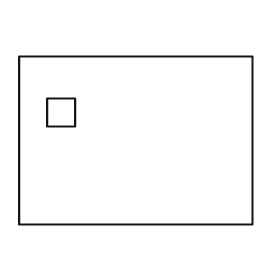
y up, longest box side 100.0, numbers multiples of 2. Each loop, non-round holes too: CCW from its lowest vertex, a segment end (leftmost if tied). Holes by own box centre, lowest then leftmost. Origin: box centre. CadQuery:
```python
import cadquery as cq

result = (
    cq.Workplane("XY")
    .moveTo(-50.0, -36.0)
    .lineTo(50.0, -36.0)
    .lineTo(50.0, 36.0)
    .lineTo(-50.0, 36.0)
    .close()
    .moveTo(-38.0, 6.0)
    .lineTo(-26.0, 6.0)
    .lineTo(-26.0, 18.0)
    .lineTo(-38.0, 18.0)
    .close()
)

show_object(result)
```